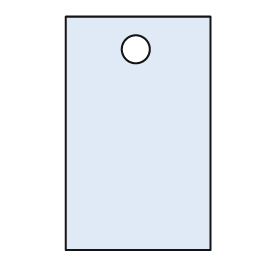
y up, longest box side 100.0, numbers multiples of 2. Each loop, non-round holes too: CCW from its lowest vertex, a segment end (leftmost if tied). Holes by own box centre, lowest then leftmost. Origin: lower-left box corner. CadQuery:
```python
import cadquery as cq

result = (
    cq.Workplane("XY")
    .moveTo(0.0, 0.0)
    .lineTo(62.0, 0.0)
    .lineTo(62.0, 100.0)
    .lineTo(0.0, 100.0)
    .close()
    .moveTo(30.0, 86.0)
    .circle(6.0)
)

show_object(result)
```